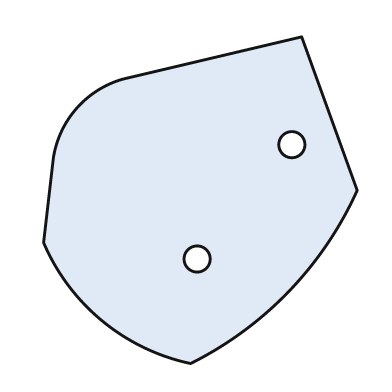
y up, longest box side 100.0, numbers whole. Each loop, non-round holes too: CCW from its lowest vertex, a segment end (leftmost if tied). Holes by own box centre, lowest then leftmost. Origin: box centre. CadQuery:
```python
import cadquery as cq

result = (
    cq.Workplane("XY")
    .moveTo(-3.0, -50.0)
    .threePointArc((27.0, -28.0), (48.0, 3.0))
    .lineTo(31.0, 50.0)
    .lineTo(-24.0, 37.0)
    .threePointArc((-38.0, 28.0), (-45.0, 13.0))
    .lineTo(-48.0, -13.0)
    .threePointArc((-30.0, -37.0), (-3.0, -50.0))
    .close()
    .moveTo(-1.0, -18.0)
    .circle(4.0)
    .moveTo(28.0, 17.0)
    .circle(4.0)
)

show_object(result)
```